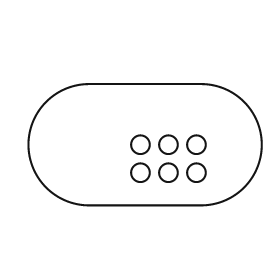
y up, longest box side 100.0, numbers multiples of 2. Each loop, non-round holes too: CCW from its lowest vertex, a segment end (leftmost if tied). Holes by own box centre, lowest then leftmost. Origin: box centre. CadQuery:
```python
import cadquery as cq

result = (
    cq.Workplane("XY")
    .moveTo(-24.0, -26.0)
    .lineTo(24.0, -26.0)
    .threePointArc((50.0, 0.0), (24.0, 26.0))
    .lineTo(-24.0, 26.0)
    .threePointArc((-50.0, 0.0), (-24.0, -26.0))
    .close()
    .moveTo(-2.0, -12.0)
    .circle(4.0)
    .moveTo(10.0, -12.0)
    .circle(4.0)
    .moveTo(22.0, -12.0)
    .circle(4.0)
    .moveTo(-2.0, 0.0)
    .circle(4.0)
    .moveTo(10.0, 0.0)
    .circle(4.0)
    .moveTo(22.0, 0.0)
    .circle(4.0)
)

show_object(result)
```